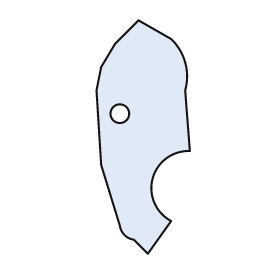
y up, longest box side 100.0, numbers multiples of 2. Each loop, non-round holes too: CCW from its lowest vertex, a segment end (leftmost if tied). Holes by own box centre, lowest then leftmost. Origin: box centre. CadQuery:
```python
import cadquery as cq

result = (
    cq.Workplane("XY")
    .moveTo(2.0, -50.0)
    .lineTo(12.0, -36.0)
    .threePointArc((4.0, -18.0), (20.0, -6.0))
    .lineTo(18.0, 20.0)
    .threePointArc((18.0, 32.0), (12.0, 42.0))
    .lineTo(-2.0, 50.0)
    .lineTo(-12.0, 40.0)
    .lineTo(-18.0, 30.0)
    .lineTo(-20.0, 20.0)
    .lineTo(-18.0, -12.0)
    .lineTo(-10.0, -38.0)
    .threePointArc((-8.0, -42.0), (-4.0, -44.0))
    .close()
    .moveTo(-10.0, 10.0)
    .circle(4.0)
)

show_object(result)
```